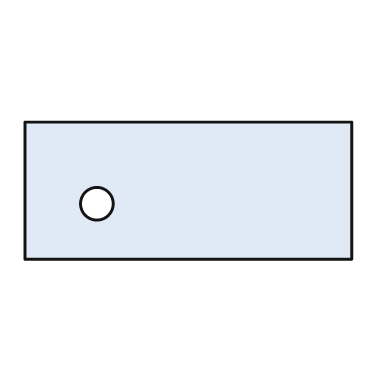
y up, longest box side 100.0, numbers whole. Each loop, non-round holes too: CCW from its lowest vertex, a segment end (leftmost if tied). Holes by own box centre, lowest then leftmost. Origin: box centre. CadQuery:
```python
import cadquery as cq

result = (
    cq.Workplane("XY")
    .moveTo(-50.0, -21.0)
    .lineTo(50.0, -21.0)
    .lineTo(50.0, 21.0)
    .lineTo(-50.0, 21.0)
    .close()
    .moveTo(-28.0, -4.0)
    .circle(5.0)
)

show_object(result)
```